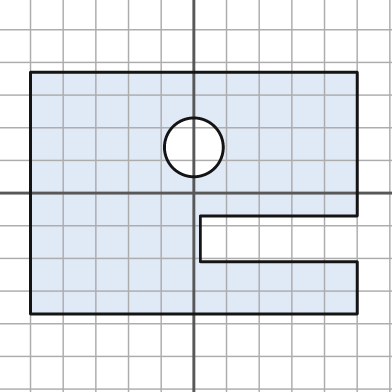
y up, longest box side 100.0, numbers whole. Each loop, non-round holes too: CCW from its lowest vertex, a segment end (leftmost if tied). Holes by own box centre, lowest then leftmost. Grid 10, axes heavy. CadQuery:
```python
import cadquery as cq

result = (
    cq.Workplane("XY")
    .moveTo(-50.0, -37.0)
    .lineTo(50.0, -37.0)
    .lineTo(50.0, -21.0)
    .lineTo(2.0, -21.0)
    .lineTo(2.0, -7.0)
    .lineTo(50.0, -7.0)
    .lineTo(50.0, 37.0)
    .lineTo(-50.0, 37.0)
    .close()
    .moveTo(0.0, 14.0)
    .circle(9.0)
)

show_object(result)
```